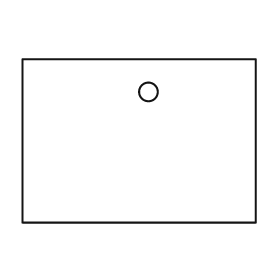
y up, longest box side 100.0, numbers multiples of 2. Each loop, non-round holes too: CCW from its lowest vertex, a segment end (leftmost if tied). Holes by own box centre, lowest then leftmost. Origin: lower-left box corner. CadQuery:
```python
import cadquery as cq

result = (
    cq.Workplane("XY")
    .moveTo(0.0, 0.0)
    .lineTo(100.0, 0.0)
    .lineTo(100.0, 70.0)
    .lineTo(0.0, 70.0)
    .close()
    .moveTo(54.0, 56.0)
    .circle(4.0)
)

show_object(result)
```